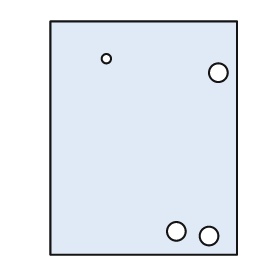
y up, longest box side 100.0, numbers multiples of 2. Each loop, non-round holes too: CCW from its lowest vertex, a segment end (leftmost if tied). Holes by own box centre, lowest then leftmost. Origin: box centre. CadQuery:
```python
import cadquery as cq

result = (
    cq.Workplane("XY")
    .moveTo(-40.0, -50.0)
    .lineTo(40.0, -50.0)
    .lineTo(40.0, 50.0)
    .lineTo(-40.0, 50.0)
    .close()
    .moveTo(28.0, -42.0)
    .circle(4.0)
    .moveTo(14.0, -40.0)
    .circle(4.0)
    .moveTo(32.0, 28.0)
    .circle(4.0)
    .moveTo(-16.0, 34.0)
    .circle(2.0)
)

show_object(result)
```